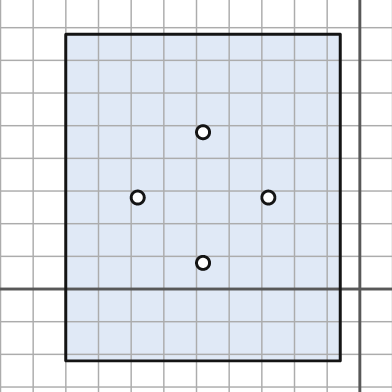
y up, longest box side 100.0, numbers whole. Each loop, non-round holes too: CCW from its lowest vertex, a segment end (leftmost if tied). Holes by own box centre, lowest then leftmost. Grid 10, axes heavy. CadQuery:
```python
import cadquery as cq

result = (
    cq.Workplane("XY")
    .moveTo(-90.0, -22.0)
    .lineTo(-6.0, -22.0)
    .lineTo(-6.0, 78.0)
    .lineTo(-90.0, 78.0)
    .close()
    .moveTo(-48.0, 8.0)
    .circle(2.0)
    .moveTo(-68.0, 28.0)
    .circle(2.0)
    .moveTo(-28.0, 28.0)
    .circle(2.0)
    .moveTo(-48.0, 48.0)
    .circle(2.0)
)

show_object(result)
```